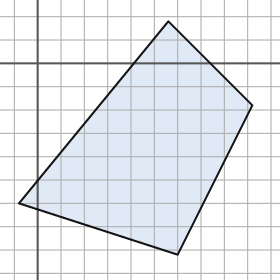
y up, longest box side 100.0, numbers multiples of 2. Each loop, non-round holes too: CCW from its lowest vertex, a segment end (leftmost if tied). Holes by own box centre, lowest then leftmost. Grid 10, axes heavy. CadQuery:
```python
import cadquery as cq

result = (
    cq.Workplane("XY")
    .moveTo(60.0, -82.0)
    .lineTo(92.0, -18.0)
    .lineTo(56.0, 18.0)
    .lineTo(-8.0, -60.0)
    .close()
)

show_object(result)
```